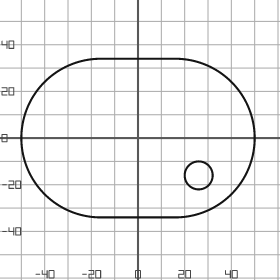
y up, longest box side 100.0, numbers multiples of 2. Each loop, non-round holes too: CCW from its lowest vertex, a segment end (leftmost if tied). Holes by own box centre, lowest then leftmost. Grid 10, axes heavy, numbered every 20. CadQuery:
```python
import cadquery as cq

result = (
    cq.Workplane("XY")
    .moveTo(-16.0, -34.0)
    .lineTo(16.0, -34.0)
    .threePointArc((50.0, 0.0), (16.0, 34.0))
    .lineTo(-16.0, 34.0)
    .threePointArc((-50.0, 0.0), (-16.0, -34.0))
    .close()
    .moveTo(26.0, -16.0)
    .circle(6.0)
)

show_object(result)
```